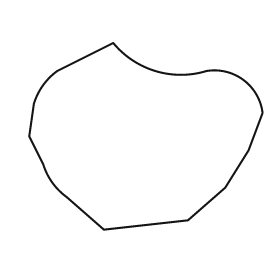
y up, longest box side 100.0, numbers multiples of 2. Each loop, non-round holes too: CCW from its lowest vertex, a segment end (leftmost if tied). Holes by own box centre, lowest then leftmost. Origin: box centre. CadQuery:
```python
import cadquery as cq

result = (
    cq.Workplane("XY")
    .moveTo(-18.0, -40.0)
    .lineTo(18.0, -36.0)
    .lineTo(34.0, -22.0)
    .lineTo(44.0, -6.0)
    .lineTo(50.0, 10.0)
    .threePointArc((42.0, 24.0), (26.0, 28.0))
    .threePointArc((4.0, 28.0), (-14.0, 40.0))
    .lineTo(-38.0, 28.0)
    .threePointArc((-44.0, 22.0), (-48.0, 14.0))
    .lineTo(-50.0, 0.0)
    .lineTo(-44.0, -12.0)
    .threePointArc((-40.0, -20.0), (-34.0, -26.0))
    .close()
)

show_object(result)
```